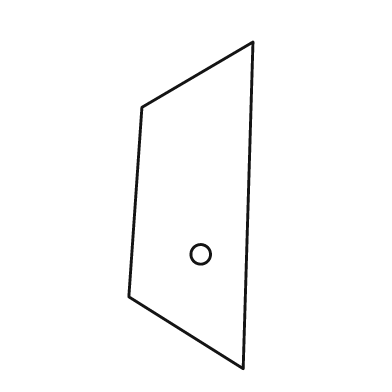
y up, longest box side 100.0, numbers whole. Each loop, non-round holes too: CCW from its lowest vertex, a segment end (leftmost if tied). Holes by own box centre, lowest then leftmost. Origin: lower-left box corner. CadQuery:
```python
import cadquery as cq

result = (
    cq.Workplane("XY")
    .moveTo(35.0, 0.0)
    .lineTo(38.0, 100.0)
    .lineTo(4.0, 80.0)
    .lineTo(0.0, 22.0)
    .close()
    .moveTo(22.0, 35.0)
    .circle(3.0)
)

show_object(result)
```